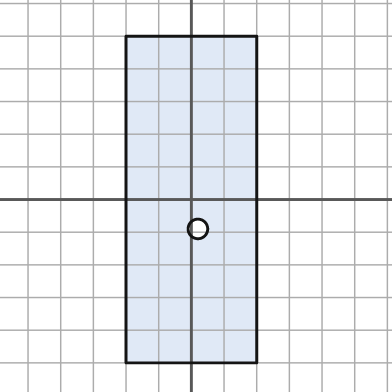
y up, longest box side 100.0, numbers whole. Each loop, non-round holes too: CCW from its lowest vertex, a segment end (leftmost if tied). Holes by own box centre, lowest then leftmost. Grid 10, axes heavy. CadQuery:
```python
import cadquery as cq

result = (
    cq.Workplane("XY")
    .moveTo(-20.0, -50.0)
    .lineTo(20.0, -50.0)
    .lineTo(20.0, 50.0)
    .lineTo(-20.0, 50.0)
    .close()
    .moveTo(2.0, -9.0)
    .circle(3.0)
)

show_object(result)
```